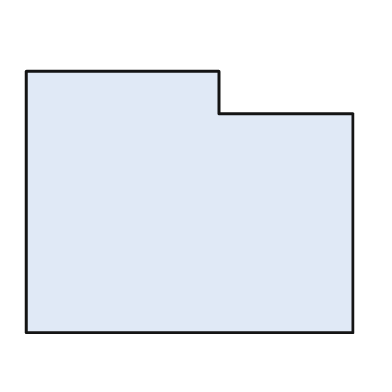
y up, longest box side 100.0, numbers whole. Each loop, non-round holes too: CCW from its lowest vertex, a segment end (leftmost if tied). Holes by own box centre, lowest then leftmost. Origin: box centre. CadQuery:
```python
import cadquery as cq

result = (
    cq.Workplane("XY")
    .moveTo(-50.0, -40.0)
    .lineTo(50.0, -40.0)
    .lineTo(50.0, 27.0)
    .lineTo(9.0, 27.0)
    .lineTo(9.0, 40.0)
    .lineTo(-50.0, 40.0)
    .close()
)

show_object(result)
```